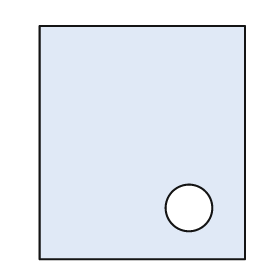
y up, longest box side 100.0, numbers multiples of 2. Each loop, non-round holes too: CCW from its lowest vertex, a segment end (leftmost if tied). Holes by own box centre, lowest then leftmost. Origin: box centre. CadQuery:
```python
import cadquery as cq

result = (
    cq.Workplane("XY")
    .moveTo(-44.0, -50.0)
    .lineTo(44.0, -50.0)
    .lineTo(44.0, 50.0)
    .lineTo(-44.0, 50.0)
    .close()
    .moveTo(20.0, -28.0)
    .circle(10.0)
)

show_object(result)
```